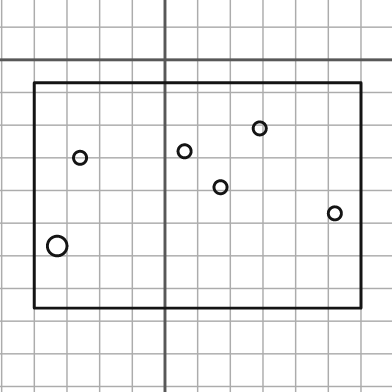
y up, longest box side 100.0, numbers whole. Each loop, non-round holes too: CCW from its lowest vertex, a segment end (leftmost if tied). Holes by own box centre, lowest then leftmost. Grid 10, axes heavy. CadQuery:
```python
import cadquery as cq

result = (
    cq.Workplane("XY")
    .moveTo(-40.0, -76.0)
    .lineTo(60.0, -76.0)
    .lineTo(60.0, -7.0)
    .lineTo(-40.0, -7.0)
    .close()
    .moveTo(-33.0, -57.0)
    .circle(3.0)
    .moveTo(52.0, -47.0)
    .circle(2.0)
    .moveTo(17.0, -39.0)
    .circle(2.0)
    .moveTo(-26.0, -30.0)
    .circle(2.0)
    .moveTo(6.0, -28.0)
    .circle(2.0)
    .moveTo(29.0, -21.0)
    .circle(2.0)
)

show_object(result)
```